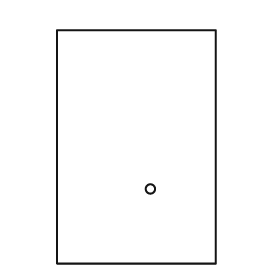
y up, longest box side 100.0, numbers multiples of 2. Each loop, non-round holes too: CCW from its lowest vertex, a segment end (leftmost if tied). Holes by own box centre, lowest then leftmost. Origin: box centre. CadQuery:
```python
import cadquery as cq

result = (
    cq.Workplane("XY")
    .moveTo(-34.0, -50.0)
    .lineTo(34.0, -50.0)
    .lineTo(34.0, 50.0)
    .lineTo(-34.0, 50.0)
    .close()
    .moveTo(6.0, -18.0)
    .circle(2.0)
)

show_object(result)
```